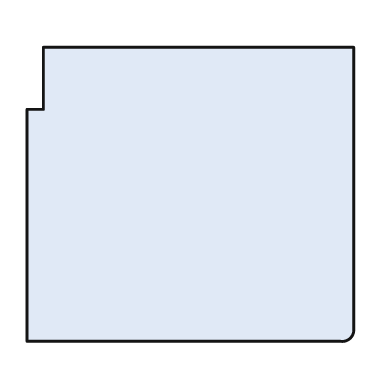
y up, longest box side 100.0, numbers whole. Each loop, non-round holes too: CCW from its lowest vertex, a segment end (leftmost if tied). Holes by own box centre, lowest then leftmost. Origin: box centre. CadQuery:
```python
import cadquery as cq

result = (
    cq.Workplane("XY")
    .moveTo(-50.0, -45.0)
    .lineTo(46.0, -45.0)
    .threePointArc((49.0, -44.0), (50.0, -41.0))
    .lineTo(50.0, 45.0)
    .lineTo(-45.0, 45.0)
    .lineTo(-45.0, 26.0)
    .lineTo(-50.0, 26.0)
    .close()
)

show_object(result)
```